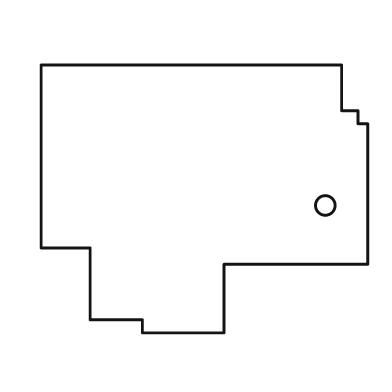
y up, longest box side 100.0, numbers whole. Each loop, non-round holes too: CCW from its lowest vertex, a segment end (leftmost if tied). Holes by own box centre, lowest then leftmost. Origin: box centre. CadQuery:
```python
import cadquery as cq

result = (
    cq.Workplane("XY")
    .moveTo(-19.0, -41.0)
    .lineTo(6.0, -41.0)
    .lineTo(6.0, -20.0)
    .lineTo(50.0, -20.0)
    .lineTo(50.0, 23.0)
    .lineTo(47.0, 23.0)
    .lineTo(47.0, 27.0)
    .lineTo(42.0, 27.0)
    .lineTo(42.0, 41.0)
    .lineTo(-50.0, 41.0)
    .lineTo(-50.0, -15.0)
    .lineTo(-35.0, -15.0)
    .lineTo(-35.0, -37.0)
    .lineTo(-19.0, -37.0)
    .close()
    .moveTo(37.0, -2.0)
    .circle(3.0)
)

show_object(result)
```